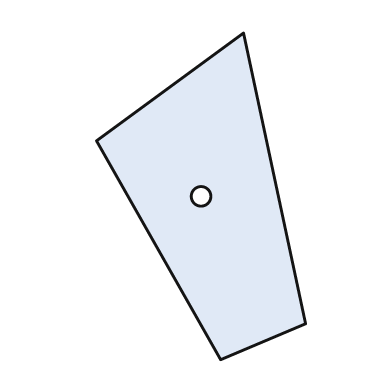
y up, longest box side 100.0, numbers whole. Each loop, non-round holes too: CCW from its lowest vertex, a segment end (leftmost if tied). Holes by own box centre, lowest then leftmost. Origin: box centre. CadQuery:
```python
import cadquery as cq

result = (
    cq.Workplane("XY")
    .moveTo(6.0, -50.0)
    .lineTo(32.0, -39.0)
    .lineTo(13.0, 50.0)
    .lineTo(-32.0, 17.0)
    .close()
    .moveTo(0.0, 0.0)
    .circle(3.0)
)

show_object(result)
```